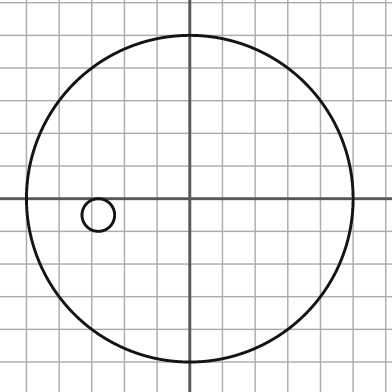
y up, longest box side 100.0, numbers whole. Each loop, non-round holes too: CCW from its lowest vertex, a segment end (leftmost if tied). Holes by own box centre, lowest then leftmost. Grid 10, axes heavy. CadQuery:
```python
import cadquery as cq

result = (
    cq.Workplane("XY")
    .moveTo(0.0, 0.0)
    .circle(50.0)
    .moveTo(-28.0, -5.0)
    .circle(5.0)
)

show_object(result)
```